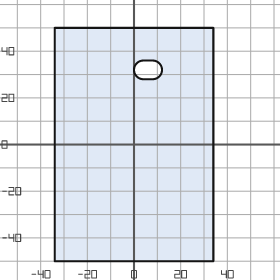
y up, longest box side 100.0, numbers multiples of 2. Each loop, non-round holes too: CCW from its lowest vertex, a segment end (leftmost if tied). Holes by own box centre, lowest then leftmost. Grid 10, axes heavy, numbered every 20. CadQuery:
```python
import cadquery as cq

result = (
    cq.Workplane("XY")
    .moveTo(-34.0, -50.0)
    .lineTo(34.0, -50.0)
    .lineTo(34.0, 50.0)
    .lineTo(-34.0, 50.0)
    .close()
    .moveTo(4.0, 28.0)
    .lineTo(8.0, 28.0)
    .threePointArc((12.0, 32.0), (8.0, 36.0))
    .lineTo(4.0, 36.0)
    .threePointArc((0.0, 32.0), (4.0, 28.0))
    .close()
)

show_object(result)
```